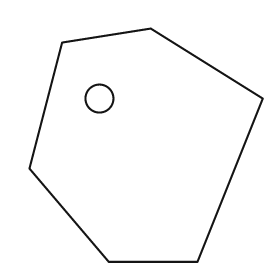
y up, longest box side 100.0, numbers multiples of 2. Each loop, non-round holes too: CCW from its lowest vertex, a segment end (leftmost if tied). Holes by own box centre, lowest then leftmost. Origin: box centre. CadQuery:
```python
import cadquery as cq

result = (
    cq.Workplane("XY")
    .moveTo(-16.0, -50.0)
    .lineTo(22.0, -50.0)
    .lineTo(50.0, 20.0)
    .lineTo(2.0, 50.0)
    .lineTo(-36.0, 44.0)
    .lineTo(-50.0, -10.0)
    .close()
    .moveTo(-20.0, 20.0)
    .circle(6.0)
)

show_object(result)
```